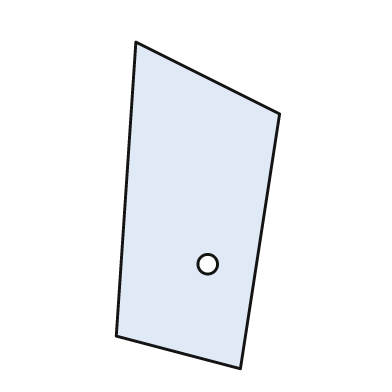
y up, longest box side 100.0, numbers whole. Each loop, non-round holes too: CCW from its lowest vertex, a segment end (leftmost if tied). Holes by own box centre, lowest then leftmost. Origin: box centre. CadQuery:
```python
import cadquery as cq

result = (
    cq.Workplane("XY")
    .moveTo(13.0, -50.0)
    .lineTo(25.0, 28.0)
    .lineTo(-19.0, 50.0)
    .lineTo(-25.0, -40.0)
    .close()
    .moveTo(3.0, -18.0)
    .circle(3.0)
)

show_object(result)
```